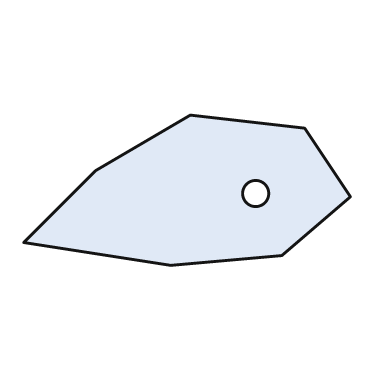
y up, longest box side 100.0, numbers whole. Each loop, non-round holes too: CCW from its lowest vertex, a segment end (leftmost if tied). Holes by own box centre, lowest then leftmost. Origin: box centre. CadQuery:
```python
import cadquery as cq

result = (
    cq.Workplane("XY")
    .moveTo(-5.0, -23.0)
    .lineTo(29.0, -20.0)
    .lineTo(50.0, -2.0)
    .lineTo(36.0, 19.0)
    .lineTo(1.0, 23.0)
    .lineTo(-28.0, 6.0)
    .lineTo(-50.0, -16.0)
    .close()
    .moveTo(21.0, -1.0)
    .circle(4.0)
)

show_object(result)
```